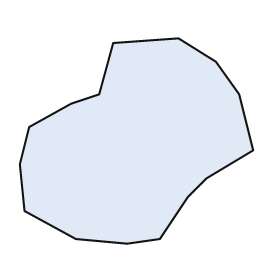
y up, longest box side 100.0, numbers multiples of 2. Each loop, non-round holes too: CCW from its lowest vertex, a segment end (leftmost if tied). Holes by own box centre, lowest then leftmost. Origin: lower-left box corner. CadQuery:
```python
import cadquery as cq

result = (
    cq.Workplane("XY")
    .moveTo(46.0, 0.0)
    .lineTo(60.0, 2.0)
    .lineTo(72.0, 20.0)
    .lineTo(80.0, 28.0)
    .lineTo(100.0, 40.0)
    .lineTo(94.0, 64.0)
    .lineTo(84.0, 78.0)
    .lineTo(68.0, 88.0)
    .lineTo(40.0, 86.0)
    .lineTo(34.0, 64.0)
    .lineTo(22.0, 60.0)
    .lineTo(4.0, 50.0)
    .lineTo(0.0, 34.0)
    .lineTo(2.0, 14.0)
    .lineTo(24.0, 2.0)
    .close()
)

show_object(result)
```